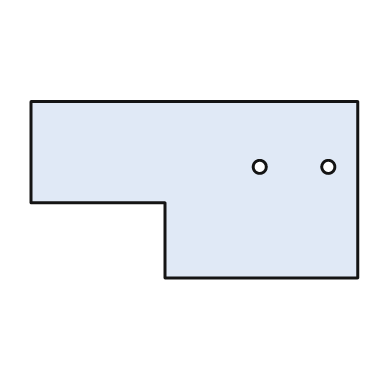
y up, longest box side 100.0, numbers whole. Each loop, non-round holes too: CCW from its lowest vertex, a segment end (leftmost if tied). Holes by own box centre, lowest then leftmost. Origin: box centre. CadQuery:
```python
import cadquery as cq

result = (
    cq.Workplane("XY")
    .moveTo(-9.0, -27.0)
    .lineTo(50.0, -27.0)
    .lineTo(50.0, 27.0)
    .lineTo(-50.0, 27.0)
    .lineTo(-50.0, -4.0)
    .lineTo(-9.0, -4.0)
    .close()
    .moveTo(20.0, 7.0)
    .circle(2.0)
    .moveTo(41.0, 7.0)
    .circle(2.0)
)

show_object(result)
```